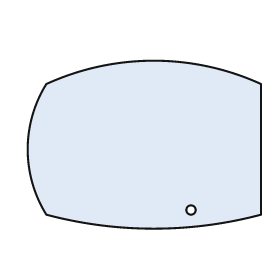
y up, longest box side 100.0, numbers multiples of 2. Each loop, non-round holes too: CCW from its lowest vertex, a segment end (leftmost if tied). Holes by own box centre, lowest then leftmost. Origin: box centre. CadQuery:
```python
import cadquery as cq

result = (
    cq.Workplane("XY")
    .moveTo(-42.0, -30.0)
    .threePointArc((4.0, -36.0), (50.0, -30.0))
    .lineTo(50.0, 26.0)
    .threePointArc((4.0, 36.0), (-42.0, 26.0))
    .threePointArc((-50.0, -2.0), (-42.0, -30.0))
    .close()
    .moveTo(20.0, -28.0)
    .circle(2.0)
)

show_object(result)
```